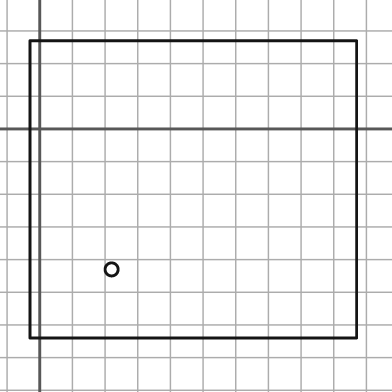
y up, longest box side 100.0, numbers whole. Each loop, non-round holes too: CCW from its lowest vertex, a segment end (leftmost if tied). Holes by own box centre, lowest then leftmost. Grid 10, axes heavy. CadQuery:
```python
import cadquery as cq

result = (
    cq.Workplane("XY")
    .moveTo(-3.0, -64.0)
    .lineTo(97.0, -64.0)
    .lineTo(97.0, 27.0)
    .lineTo(-3.0, 27.0)
    .close()
    .moveTo(22.0, -43.0)
    .circle(2.0)
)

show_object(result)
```